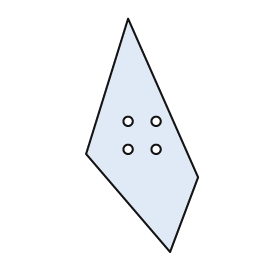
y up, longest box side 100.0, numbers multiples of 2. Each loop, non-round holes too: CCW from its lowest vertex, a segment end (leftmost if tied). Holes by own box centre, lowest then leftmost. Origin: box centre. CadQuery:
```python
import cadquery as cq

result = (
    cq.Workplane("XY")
    .moveTo(12.0, -50.0)
    .lineTo(24.0, -18.0)
    .lineTo(-6.0, 50.0)
    .lineTo(-24.0, -8.0)
    .close()
    .moveTo(-6.0, -6.0)
    .circle(2.0)
    .moveTo(6.0, -6.0)
    .circle(2.0)
    .moveTo(-6.0, 6.0)
    .circle(2.0)
    .moveTo(6.0, 6.0)
    .circle(2.0)
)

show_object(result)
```